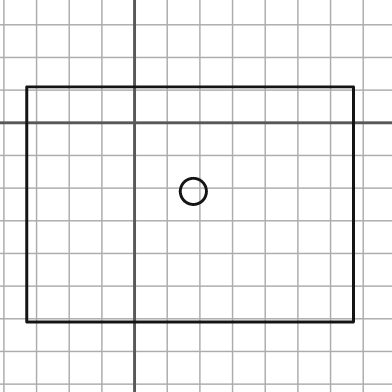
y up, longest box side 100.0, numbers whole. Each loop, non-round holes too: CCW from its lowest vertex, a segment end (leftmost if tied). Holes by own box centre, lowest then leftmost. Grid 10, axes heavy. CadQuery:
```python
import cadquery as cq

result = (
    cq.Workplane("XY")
    .moveTo(-33.0, -61.0)
    .lineTo(67.0, -61.0)
    .lineTo(67.0, 11.0)
    .lineTo(-33.0, 11.0)
    .close()
    .moveTo(18.0, -21.0)
    .circle(4.0)
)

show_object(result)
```